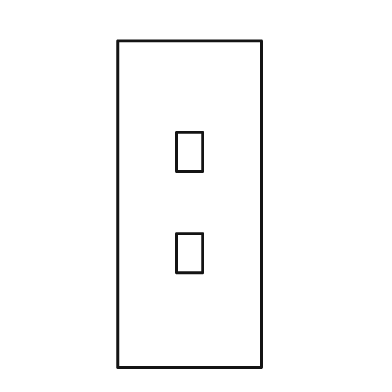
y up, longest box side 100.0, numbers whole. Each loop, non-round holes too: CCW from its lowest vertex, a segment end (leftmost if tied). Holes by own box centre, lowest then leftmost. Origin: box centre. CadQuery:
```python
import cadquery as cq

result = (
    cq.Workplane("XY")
    .moveTo(-22.0, -50.0)
    .lineTo(22.0, -50.0)
    .lineTo(22.0, 50.0)
    .lineTo(-22.0, 50.0)
    .close()
    .moveTo(-4.0, -21.0)
    .lineTo(4.0, -21.0)
    .lineTo(4.0, -9.0)
    .lineTo(-4.0, -9.0)
    .close()
    .moveTo(-4.0, 10.0)
    .lineTo(4.0, 10.0)
    .lineTo(4.0, 22.0)
    .lineTo(-4.0, 22.0)
    .close()
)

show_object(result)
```